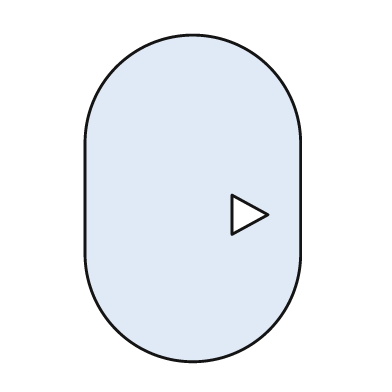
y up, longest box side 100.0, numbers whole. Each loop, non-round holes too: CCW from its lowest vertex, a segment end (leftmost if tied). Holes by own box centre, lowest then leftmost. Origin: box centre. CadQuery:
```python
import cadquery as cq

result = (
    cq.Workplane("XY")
    .moveTo(-33.0, -17.0)
    .threePointArc((0.0, -50.0), (33.0, -17.0))
    .lineTo(33.0, 17.0)
    .threePointArc((0.0, 50.0), (-33.0, 17.0))
    .close()
    .moveTo(12.0, -11.0)
    .lineTo(23.0, -5.0)
    .lineTo(12.0, 1.0)
    .close()
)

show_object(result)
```